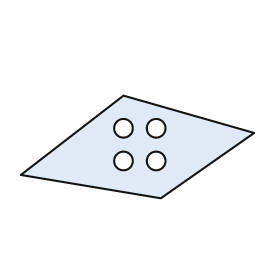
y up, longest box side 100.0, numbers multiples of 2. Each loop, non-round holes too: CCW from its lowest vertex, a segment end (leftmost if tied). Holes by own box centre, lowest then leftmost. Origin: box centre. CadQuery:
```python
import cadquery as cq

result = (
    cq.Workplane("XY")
    .moveTo(10.0, -22.0)
    .lineTo(50.0, 6.0)
    .lineTo(-6.0, 22.0)
    .lineTo(-50.0, -12.0)
    .close()
    .moveTo(-6.0, -6.0)
    .circle(4.0)
    .moveTo(8.0, -6.0)
    .circle(4.0)
    .moveTo(-6.0, 8.0)
    .circle(4.0)
    .moveTo(8.0, 8.0)
    .circle(4.0)
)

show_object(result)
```